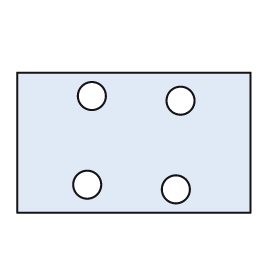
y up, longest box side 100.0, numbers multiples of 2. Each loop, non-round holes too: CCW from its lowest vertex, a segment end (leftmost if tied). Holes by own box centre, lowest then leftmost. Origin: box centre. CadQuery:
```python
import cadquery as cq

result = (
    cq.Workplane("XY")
    .moveTo(-50.0, -30.0)
    .lineTo(50.0, -30.0)
    .lineTo(50.0, 30.0)
    .lineTo(-50.0, 30.0)
    .close()
    .moveTo(18.0, -20.0)
    .circle(6.0)
    .moveTo(-20.0, -18.0)
    .circle(6.0)
    .moveTo(20.0, 18.0)
    .circle(6.0)
    .moveTo(-18.0, 20.0)
    .circle(6.0)
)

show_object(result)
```